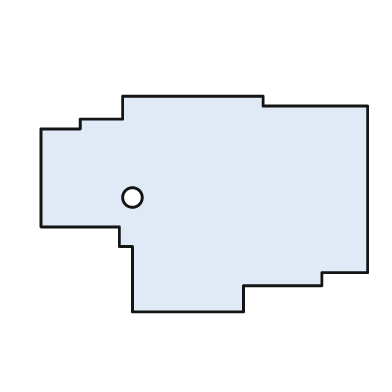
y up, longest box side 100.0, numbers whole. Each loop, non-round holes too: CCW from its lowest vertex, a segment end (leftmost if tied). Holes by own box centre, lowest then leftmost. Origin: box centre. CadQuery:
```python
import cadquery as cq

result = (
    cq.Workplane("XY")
    .moveTo(-22.0, -33.0)
    .lineTo(12.0, -33.0)
    .lineTo(12.0, -25.0)
    .lineTo(36.0, -25.0)
    .lineTo(36.0, -21.0)
    .lineTo(50.0, -21.0)
    .lineTo(50.0, 30.0)
    .lineTo(18.0, 30.0)
    .lineTo(18.0, 33.0)
    .lineTo(-25.0, 33.0)
    .lineTo(-25.0, 26.0)
    .lineTo(-38.0, 26.0)
    .lineTo(-38.0, 23.0)
    .lineTo(-50.0, 23.0)
    .lineTo(-50.0, -7.0)
    .lineTo(-26.0, -7.0)
    .lineTo(-26.0, -13.0)
    .lineTo(-22.0, -13.0)
    .close()
    .moveTo(-22.0, 2.0)
    .circle(3.0)
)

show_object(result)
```